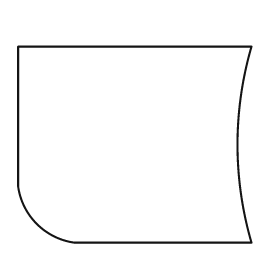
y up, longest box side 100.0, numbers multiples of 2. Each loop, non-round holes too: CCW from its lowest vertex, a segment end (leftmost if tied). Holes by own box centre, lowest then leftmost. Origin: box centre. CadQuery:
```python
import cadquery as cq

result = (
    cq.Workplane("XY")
    .moveTo(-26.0, -42.0)
    .lineTo(50.0, -42.0)
    .threePointArc((44.0, 0.0), (50.0, 42.0))
    .lineTo(-50.0, 42.0)
    .lineTo(-50.0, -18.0)
    .threePointArc((-42.0, -34.0), (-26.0, -42.0))
    .close()
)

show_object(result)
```